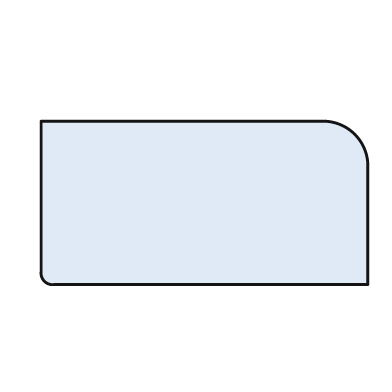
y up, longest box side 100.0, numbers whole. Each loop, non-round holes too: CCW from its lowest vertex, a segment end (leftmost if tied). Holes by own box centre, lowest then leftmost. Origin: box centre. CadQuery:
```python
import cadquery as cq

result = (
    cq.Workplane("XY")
    .moveTo(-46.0, -25.0)
    .lineTo(50.0, -25.0)
    .lineTo(50.0, 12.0)
    .threePointArc((46.0, 21.0), (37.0, 25.0))
    .lineTo(-50.0, 25.0)
    .lineTo(-50.0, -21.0)
    .threePointArc((-49.0, -24.0), (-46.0, -25.0))
    .close()
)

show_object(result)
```